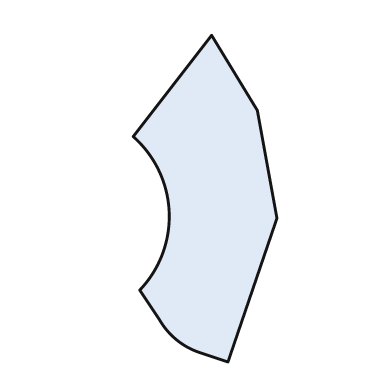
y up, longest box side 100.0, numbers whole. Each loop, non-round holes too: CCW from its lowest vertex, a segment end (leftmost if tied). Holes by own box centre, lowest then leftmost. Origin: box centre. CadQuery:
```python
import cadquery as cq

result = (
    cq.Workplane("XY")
    .moveTo(7.0, -50.0)
    .lineTo(22.0, -6.0)
    .lineTo(16.0, 27.0)
    .lineTo(2.0, 50.0)
    .lineTo(-22.0, 19.0)
    .threePointArc((-11.0, -4.0), (-20.0, -28.0))
    .lineTo(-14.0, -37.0)
    .threePointArc((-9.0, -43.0), (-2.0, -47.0))
    .close()
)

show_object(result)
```